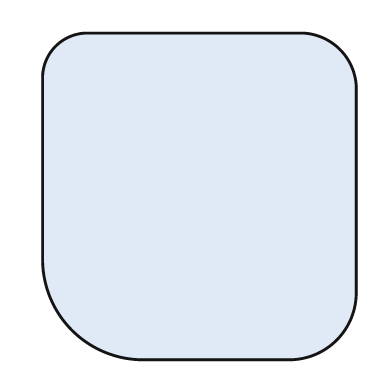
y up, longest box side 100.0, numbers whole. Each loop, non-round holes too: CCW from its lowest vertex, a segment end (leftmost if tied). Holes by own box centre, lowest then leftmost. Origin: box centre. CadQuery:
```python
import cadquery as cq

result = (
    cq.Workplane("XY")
    .moveTo(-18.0, -50.0)
    .lineTo(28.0, -50.0)
    .threePointArc((42.0, -44.0), (48.0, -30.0))
    .lineTo(48.0, 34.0)
    .threePointArc((43.0, 45.0), (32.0, 50.0))
    .lineTo(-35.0, 50.0)
    .threePointArc((-44.0, 46.0), (-48.0, 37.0))
    .lineTo(-48.0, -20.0)
    .threePointArc((-39.0, -41.0), (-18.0, -50.0))
    .close()
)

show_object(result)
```